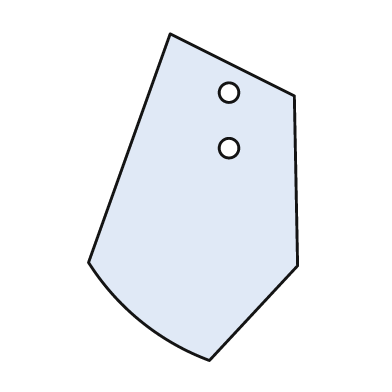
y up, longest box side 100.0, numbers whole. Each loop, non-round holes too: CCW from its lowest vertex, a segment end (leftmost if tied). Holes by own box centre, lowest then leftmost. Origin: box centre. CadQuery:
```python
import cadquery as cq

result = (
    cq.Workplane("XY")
    .moveTo(5.0, -50.0)
    .lineTo(32.0, -21.0)
    .lineTo(31.0, 31.0)
    .lineTo(-7.0, 50.0)
    .lineTo(-32.0, -20.0)
    .threePointArc((-16.0, -38.0), (5.0, -50.0))
    .close()
    .moveTo(11.0, 15.0)
    .circle(3.0)
    .moveTo(11.0, 32.0)
    .circle(3.0)
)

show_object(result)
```